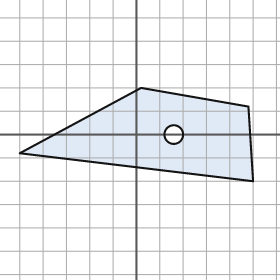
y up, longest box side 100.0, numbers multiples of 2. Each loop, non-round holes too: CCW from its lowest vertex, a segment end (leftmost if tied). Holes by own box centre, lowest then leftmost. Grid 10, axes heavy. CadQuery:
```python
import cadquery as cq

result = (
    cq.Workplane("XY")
    .moveTo(50.0, -20.0)
    .lineTo(48.0, 12.0)
    .lineTo(2.0, 20.0)
    .lineTo(-50.0, -8.0)
    .close()
    .moveTo(16.0, 0.0)
    .circle(4.0)
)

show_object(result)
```